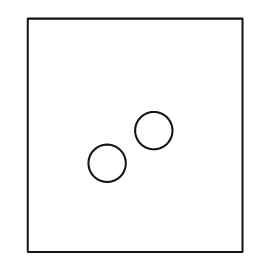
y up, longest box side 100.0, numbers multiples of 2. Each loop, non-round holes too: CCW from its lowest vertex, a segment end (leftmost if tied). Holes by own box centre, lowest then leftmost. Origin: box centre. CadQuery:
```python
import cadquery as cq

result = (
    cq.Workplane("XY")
    .moveTo(-46.0, -50.0)
    .lineTo(46.0, -50.0)
    .lineTo(46.0, 50.0)
    .lineTo(-46.0, 50.0)
    .close()
    .moveTo(-12.0, -12.0)
    .circle(8.0)
    .moveTo(8.0, 2.0)
    .circle(8.0)
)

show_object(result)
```